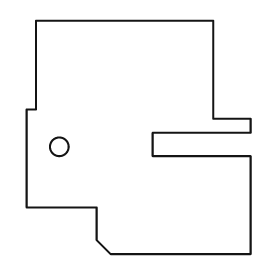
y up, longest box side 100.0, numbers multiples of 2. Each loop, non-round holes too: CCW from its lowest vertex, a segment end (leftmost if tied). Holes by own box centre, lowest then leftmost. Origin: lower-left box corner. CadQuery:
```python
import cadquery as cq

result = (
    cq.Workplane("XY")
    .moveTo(36.0, 0.0)
    .lineTo(96.0, 0.0)
    .lineTo(96.0, 42.0)
    .lineTo(54.0, 42.0)
    .lineTo(54.0, 52.0)
    .lineTo(96.0, 52.0)
    .lineTo(96.0, 58.0)
    .lineTo(80.0, 58.0)
    .lineTo(80.0, 100.0)
    .lineTo(4.0, 100.0)
    .lineTo(4.0, 62.0)
    .lineTo(0.0, 62.0)
    .lineTo(0.0, 20.0)
    .lineTo(30.0, 20.0)
    .lineTo(30.0, 6.0)
    .close()
    .moveTo(14.0, 46.0)
    .circle(4.0)
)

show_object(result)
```